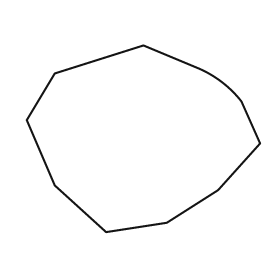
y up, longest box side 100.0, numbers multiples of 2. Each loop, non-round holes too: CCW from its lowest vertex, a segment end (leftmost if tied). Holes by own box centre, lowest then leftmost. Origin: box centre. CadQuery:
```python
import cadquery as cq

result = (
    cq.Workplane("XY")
    .moveTo(-16.0, -40.0)
    .lineTo(10.0, -36.0)
    .lineTo(32.0, -22.0)
    .lineTo(50.0, -2.0)
    .lineTo(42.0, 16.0)
    .threePointArc((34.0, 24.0), (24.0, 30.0))
    .lineTo(0.0, 40.0)
    .lineTo(-38.0, 28.0)
    .lineTo(-50.0, 8.0)
    .lineTo(-38.0, -20.0)
    .close()
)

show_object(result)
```